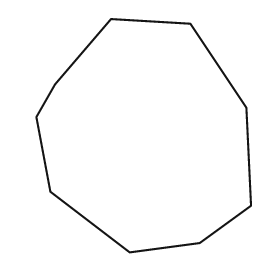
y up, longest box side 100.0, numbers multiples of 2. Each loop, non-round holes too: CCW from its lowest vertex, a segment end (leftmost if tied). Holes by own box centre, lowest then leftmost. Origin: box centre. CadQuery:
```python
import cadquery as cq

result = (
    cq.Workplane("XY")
    .moveTo(-6.0, -50.0)
    .lineTo(24.0, -46.0)
    .lineTo(46.0, -30.0)
    .lineTo(44.0, 12.0)
    .lineTo(20.0, 48.0)
    .lineTo(-14.0, 50.0)
    .lineTo(-38.0, 22.0)
    .lineTo(-46.0, 8.0)
    .lineTo(-40.0, -24.0)
    .close()
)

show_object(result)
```